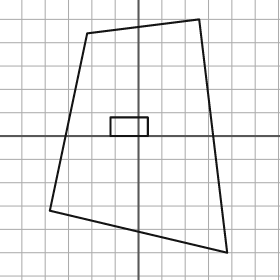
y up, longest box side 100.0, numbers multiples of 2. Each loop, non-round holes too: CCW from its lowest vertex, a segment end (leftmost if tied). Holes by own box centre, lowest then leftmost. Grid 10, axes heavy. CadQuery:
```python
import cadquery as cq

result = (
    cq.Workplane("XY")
    .moveTo(38.0, -50.0)
    .lineTo(26.0, 50.0)
    .lineTo(-22.0, 44.0)
    .lineTo(-38.0, -32.0)
    .close()
    .moveTo(-12.0, 0.0)
    .lineTo(4.0, 0.0)
    .lineTo(4.0, 8.0)
    .lineTo(-12.0, 8.0)
    .close()
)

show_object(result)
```